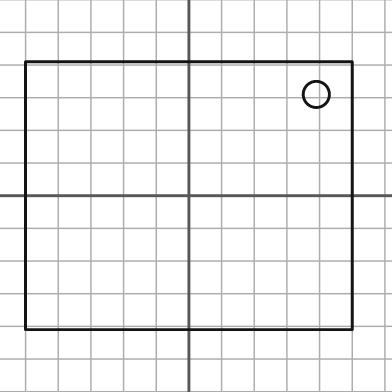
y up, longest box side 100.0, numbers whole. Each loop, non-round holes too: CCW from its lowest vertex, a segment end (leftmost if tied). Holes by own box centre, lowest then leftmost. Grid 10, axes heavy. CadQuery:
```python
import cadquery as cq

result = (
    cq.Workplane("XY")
    .moveTo(-50.0, -41.0)
    .lineTo(50.0, -41.0)
    .lineTo(50.0, 41.0)
    .lineTo(-50.0, 41.0)
    .close()
    .moveTo(39.0, 31.0)
    .circle(4.0)
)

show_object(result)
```